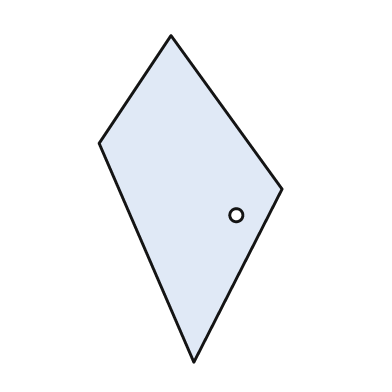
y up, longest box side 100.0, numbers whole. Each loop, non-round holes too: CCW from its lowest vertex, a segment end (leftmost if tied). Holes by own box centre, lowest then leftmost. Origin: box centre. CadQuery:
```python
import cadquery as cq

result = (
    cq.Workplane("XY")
    .moveTo(1.0, -50.0)
    .lineTo(28.0, 3.0)
    .lineTo(-6.0, 50.0)
    .lineTo(-28.0, 17.0)
    .close()
    .moveTo(14.0, -5.0)
    .circle(2.0)
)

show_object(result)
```